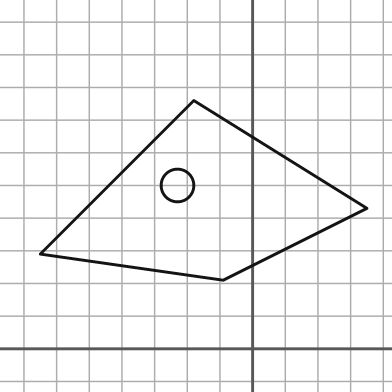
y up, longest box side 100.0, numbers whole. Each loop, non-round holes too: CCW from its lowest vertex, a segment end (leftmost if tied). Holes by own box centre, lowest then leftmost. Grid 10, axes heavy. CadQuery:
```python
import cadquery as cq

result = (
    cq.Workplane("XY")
    .moveTo(-9.0, 21.0)
    .lineTo(35.0, 43.0)
    .lineTo(-18.0, 76.0)
    .lineTo(-65.0, 29.0)
    .close()
    .moveTo(-23.0, 50.0)
    .circle(5.0)
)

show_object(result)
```